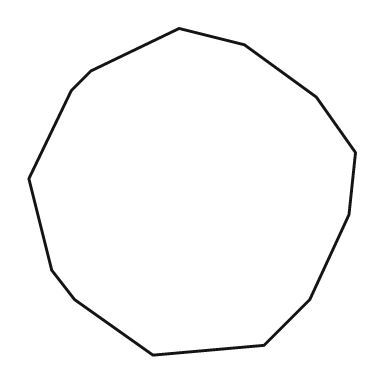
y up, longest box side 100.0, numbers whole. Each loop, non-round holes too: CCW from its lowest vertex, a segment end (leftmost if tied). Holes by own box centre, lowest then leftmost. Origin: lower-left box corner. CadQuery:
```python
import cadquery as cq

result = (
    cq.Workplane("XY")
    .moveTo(38.0, 0.0)
    .lineTo(72.0, 3.0)
    .lineTo(86.0, 17.0)
    .lineTo(98.0, 43.0)
    .lineTo(100.0, 62.0)
    .lineTo(88.0, 79.0)
    .lineTo(66.0, 95.0)
    .lineTo(46.0, 100.0)
    .lineTo(19.0, 87.0)
    .lineTo(13.0, 81.0)
    .lineTo(0.0, 54.0)
    .lineTo(7.0, 26.0)
    .lineTo(14.0, 17.0)
    .close()
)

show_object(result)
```